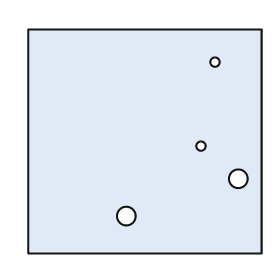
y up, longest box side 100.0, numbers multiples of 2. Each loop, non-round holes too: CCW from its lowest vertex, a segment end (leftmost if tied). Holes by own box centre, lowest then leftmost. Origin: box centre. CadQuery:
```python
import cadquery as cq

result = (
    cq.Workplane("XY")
    .moveTo(-50.0, -48.0)
    .lineTo(50.0, -48.0)
    .lineTo(50.0, 48.0)
    .lineTo(-50.0, 48.0)
    .close()
    .moveTo(-8.0, -32.0)
    .circle(4.0)
    .moveTo(40.0, -16.0)
    .circle(4.0)
    .moveTo(24.0, -2.0)
    .circle(2.0)
    .moveTo(30.0, 34.0)
    .circle(2.0)
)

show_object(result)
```